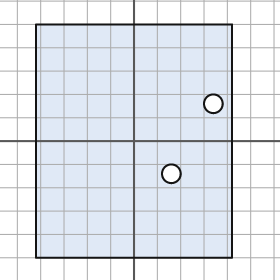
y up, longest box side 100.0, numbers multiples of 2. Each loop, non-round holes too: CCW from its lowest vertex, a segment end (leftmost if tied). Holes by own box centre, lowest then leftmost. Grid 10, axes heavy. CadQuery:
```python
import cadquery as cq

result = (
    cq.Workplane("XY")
    .moveTo(-42.0, -50.0)
    .lineTo(42.0, -50.0)
    .lineTo(42.0, 50.0)
    .lineTo(-42.0, 50.0)
    .close()
    .moveTo(16.0, -14.0)
    .circle(4.0)
    .moveTo(34.0, 16.0)
    .circle(4.0)
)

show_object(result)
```